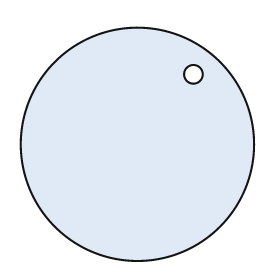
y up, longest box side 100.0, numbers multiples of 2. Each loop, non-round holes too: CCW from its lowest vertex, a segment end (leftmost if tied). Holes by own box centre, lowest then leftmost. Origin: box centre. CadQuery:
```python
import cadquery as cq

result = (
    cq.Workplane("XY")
    .moveTo(0.0, 0.0)
    .circle(50.0)
    .moveTo(24.0, 30.0)
    .circle(4.0)
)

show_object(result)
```